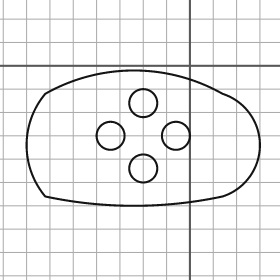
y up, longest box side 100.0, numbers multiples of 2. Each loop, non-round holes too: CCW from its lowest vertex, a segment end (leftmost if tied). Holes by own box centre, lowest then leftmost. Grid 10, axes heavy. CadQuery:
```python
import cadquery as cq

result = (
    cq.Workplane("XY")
    .moveTo(-62.0, -56.0)
    .threePointArc((-24.0, -60.0), (14.0, -56.0))
    .threePointArc((30.0, -34.0), (14.0, -12.0))
    .threePointArc((-24.0, -2.0), (-62.0, -12.0))
    .threePointArc((-70.0, -34.0), (-62.0, -56.0))
    .close()
    .moveTo(-20.0, -44.0)
    .circle(6.0)
    .moveTo(-34.0, -30.0)
    .circle(6.0)
    .moveTo(-6.0, -30.0)
    .circle(6.0)
    .moveTo(-20.0, -16.0)
    .circle(6.0)
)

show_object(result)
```